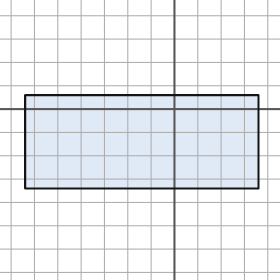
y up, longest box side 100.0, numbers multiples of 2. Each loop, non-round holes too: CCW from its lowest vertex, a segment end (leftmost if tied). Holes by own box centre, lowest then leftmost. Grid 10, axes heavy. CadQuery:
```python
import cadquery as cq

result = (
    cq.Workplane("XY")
    .moveTo(-64.0, -34.0)
    .lineTo(36.0, -34.0)
    .lineTo(36.0, 6.0)
    .lineTo(-64.0, 6.0)
    .close()
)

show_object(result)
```